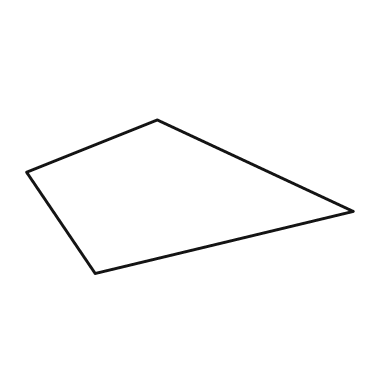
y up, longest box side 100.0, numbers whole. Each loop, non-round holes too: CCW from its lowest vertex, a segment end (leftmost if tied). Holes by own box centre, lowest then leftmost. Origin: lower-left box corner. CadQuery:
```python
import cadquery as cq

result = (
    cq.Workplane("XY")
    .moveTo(21.0, 0.0)
    .lineTo(100.0, 19.0)
    .lineTo(40.0, 47.0)
    .lineTo(0.0, 31.0)
    .close()
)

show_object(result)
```